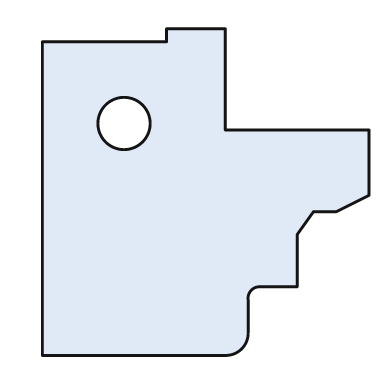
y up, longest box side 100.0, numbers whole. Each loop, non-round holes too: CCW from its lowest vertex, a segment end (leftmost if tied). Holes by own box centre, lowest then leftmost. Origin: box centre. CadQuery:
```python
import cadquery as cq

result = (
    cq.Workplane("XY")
    .moveTo(-50.0, -50.0)
    .lineTo(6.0, -50.0)
    .threePointArc((11.0, -48.0), (13.0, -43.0))
    .lineTo(13.0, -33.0)
    .threePointArc((14.0, -30.0), (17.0, -29.0))
    .lineTo(28.0, -29.0)
    .lineTo(28.0, -13.0)
    .lineTo(33.0, -6.0)
    .lineTo(40.0, -6.0)
    .lineTo(50.0, -1.0)
    .lineTo(50.0, 19.0)
    .lineTo(6.0, 19.0)
    .lineTo(6.0, 50.0)
    .lineTo(-12.0, 50.0)
    .lineTo(-12.0, 46.0)
    .lineTo(-50.0, 46.0)
    .close()
    .moveTo(-25.0, 21.0)
    .circle(8.0)
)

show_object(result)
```